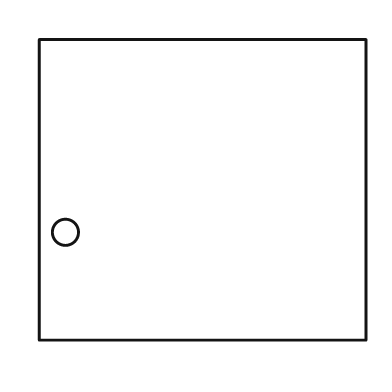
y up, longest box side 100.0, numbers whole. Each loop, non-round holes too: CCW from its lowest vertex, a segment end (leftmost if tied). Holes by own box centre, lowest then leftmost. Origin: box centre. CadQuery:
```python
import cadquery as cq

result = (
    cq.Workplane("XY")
    .moveTo(-50.0, -46.0)
    .lineTo(50.0, -46.0)
    .lineTo(50.0, 46.0)
    .lineTo(-50.0, 46.0)
    .close()
    .moveTo(-42.0, -13.0)
    .circle(4.0)
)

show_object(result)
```